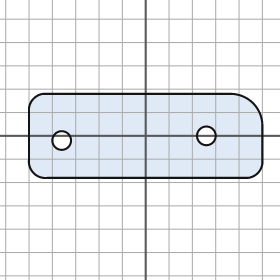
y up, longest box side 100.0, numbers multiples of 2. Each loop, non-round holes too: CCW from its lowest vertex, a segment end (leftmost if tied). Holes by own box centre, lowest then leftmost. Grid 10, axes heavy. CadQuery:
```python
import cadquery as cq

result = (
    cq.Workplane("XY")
    .moveTo(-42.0, -18.0)
    .lineTo(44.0, -18.0)
    .threePointArc((48.0, -16.0), (50.0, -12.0))
    .lineTo(50.0, 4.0)
    .threePointArc((46.0, 14.0), (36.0, 18.0))
    .lineTo(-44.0, 18.0)
    .threePointArc((-48.0, 16.0), (-50.0, 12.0))
    .lineTo(-50.0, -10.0)
    .threePointArc((-48.0, -16.0), (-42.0, -18.0))
    .close()
    .moveTo(-36.0, -2.0)
    .circle(4.0)
    .moveTo(26.0, 0.0)
    .circle(4.0)
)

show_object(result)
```